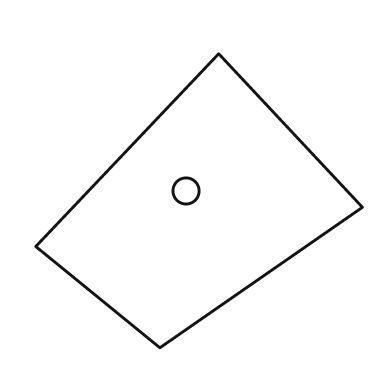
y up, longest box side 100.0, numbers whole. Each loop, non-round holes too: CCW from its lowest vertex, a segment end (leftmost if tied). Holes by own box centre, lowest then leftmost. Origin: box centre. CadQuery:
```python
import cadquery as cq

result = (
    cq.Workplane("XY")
    .moveTo(-12.0, -45.0)
    .lineTo(50.0, -2.0)
    .lineTo(6.0, 45.0)
    .lineTo(-50.0, -14.0)
    .close()
    .moveTo(-4.0, 3.0)
    .circle(4.0)
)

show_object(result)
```